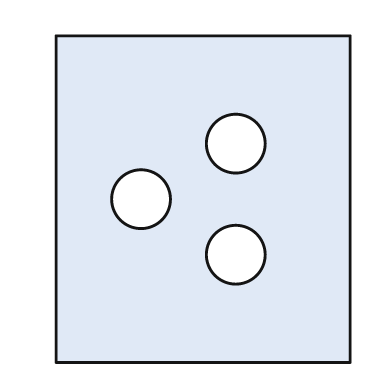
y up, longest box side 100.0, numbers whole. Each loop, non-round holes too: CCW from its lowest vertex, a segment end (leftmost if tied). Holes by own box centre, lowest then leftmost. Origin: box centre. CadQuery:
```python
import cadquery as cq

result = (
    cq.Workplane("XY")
    .moveTo(-45.0, -50.0)
    .lineTo(45.0, -50.0)
    .lineTo(45.0, 50.0)
    .lineTo(-45.0, 50.0)
    .close()
    .moveTo(10.0, -17.0)
    .circle(9.0)
    .moveTo(-19.0, 0.0)
    .circle(9.0)
    .moveTo(10.0, 17.0)
    .circle(9.0)
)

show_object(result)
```